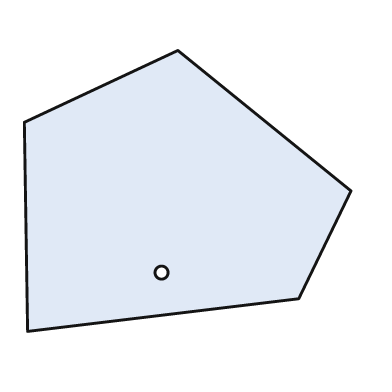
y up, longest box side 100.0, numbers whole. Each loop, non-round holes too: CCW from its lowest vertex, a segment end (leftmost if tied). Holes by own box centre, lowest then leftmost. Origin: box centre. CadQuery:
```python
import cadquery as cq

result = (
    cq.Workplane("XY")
    .moveTo(-49.0, -43.0)
    .lineTo(34.0, -33.0)
    .lineTo(50.0, 0.0)
    .lineTo(-3.0, 43.0)
    .lineTo(-50.0, 21.0)
    .close()
    .moveTo(-8.0, -25.0)
    .circle(2.0)
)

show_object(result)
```